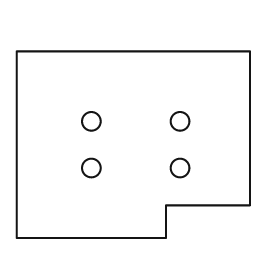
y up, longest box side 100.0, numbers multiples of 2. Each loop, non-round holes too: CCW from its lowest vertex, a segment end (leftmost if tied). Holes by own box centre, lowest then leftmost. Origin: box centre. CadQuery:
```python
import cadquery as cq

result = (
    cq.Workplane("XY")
    .moveTo(-50.0, -40.0)
    .lineTo(14.0, -40.0)
    .lineTo(14.0, -26.0)
    .lineTo(50.0, -26.0)
    .lineTo(50.0, 40.0)
    .lineTo(-50.0, 40.0)
    .close()
    .moveTo(-18.0, -10.0)
    .circle(4.0)
    .moveTo(20.0, -10.0)
    .circle(4.0)
    .moveTo(-18.0, 10.0)
    .circle(4.0)
    .moveTo(20.0, 10.0)
    .circle(4.0)
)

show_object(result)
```